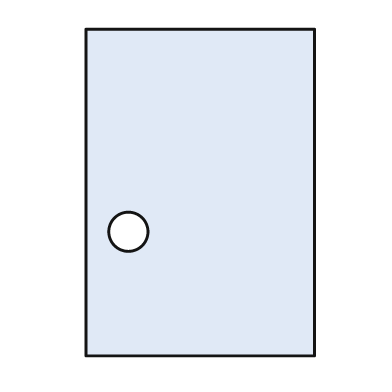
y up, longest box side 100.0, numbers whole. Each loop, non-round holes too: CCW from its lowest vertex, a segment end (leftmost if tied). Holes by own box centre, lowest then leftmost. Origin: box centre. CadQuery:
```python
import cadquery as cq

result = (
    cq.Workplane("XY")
    .moveTo(-35.0, -50.0)
    .lineTo(35.0, -50.0)
    .lineTo(35.0, 50.0)
    .lineTo(-35.0, 50.0)
    .close()
    .moveTo(-22.0, -12.0)
    .circle(6.0)
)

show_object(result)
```